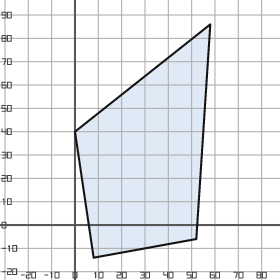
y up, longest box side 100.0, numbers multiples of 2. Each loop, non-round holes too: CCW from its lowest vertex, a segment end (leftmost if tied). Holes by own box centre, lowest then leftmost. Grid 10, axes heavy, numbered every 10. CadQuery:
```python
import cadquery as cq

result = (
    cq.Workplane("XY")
    .moveTo(8.0, -14.0)
    .lineTo(52.0, -6.0)
    .lineTo(58.0, 86.0)
    .lineTo(0.0, 40.0)
    .close()
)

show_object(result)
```